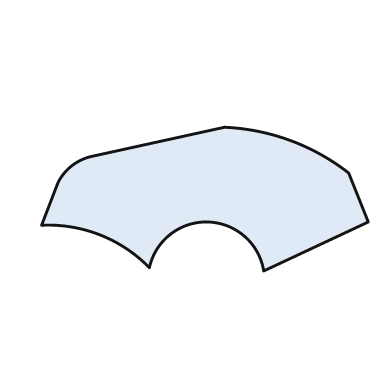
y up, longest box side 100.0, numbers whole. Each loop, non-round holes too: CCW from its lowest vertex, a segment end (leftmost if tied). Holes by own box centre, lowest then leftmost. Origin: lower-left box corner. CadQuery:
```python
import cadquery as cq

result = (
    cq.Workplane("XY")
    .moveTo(68.0, 0.0)
    .lineTo(100.0, 15.0)
    .lineTo(94.0, 30.0)
    .threePointArc((76.0, 40.0), (56.0, 44.0))
    .lineTo(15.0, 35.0)
    .threePointArc((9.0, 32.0), (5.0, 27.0))
    .lineTo(0.0, 14.0)
    .threePointArc((18.0, 11.0), (33.0, 1.0))
    .threePointArc((51.0, 15.0), (68.0, 0.0))
    .close()
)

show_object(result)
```